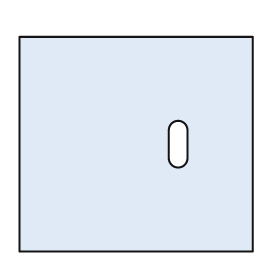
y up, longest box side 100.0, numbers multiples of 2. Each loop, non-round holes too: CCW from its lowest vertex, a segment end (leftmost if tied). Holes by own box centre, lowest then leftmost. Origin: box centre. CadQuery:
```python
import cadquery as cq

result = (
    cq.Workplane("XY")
    .moveTo(-50.0, -46.0)
    .lineTo(50.0, -46.0)
    .lineTo(50.0, 46.0)
    .lineTo(-50.0, 46.0)
    .close()
    .moveTo(14.0, -6.0)
    .threePointArc((18.0, -10.0), (22.0, -6.0))
    .lineTo(22.0, 6.0)
    .threePointArc((18.0, 10.0), (14.0, 6.0))
    .close()
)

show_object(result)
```